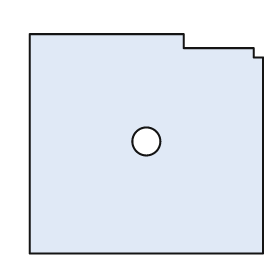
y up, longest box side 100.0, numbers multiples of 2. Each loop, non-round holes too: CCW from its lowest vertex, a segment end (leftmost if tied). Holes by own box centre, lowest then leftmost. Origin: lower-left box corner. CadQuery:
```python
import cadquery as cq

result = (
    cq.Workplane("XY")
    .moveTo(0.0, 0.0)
    .lineTo(100.0, 0.0)
    .lineTo(100.0, 84.0)
    .lineTo(96.0, 84.0)
    .lineTo(96.0, 88.0)
    .lineTo(66.0, 88.0)
    .lineTo(66.0, 94.0)
    .lineTo(0.0, 94.0)
    .close()
    .moveTo(50.0, 48.0)
    .circle(6.0)
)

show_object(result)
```